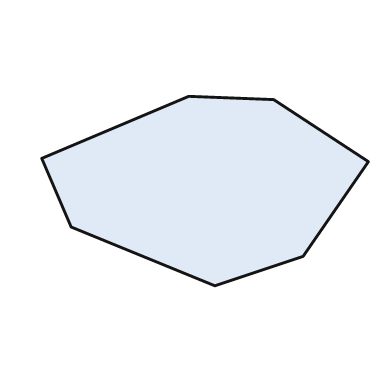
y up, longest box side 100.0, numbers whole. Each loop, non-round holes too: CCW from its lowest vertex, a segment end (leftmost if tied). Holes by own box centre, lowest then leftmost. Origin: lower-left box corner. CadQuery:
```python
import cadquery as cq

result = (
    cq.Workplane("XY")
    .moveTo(53.0, 0.0)
    .lineTo(80.0, 9.0)
    .lineTo(100.0, 38.0)
    .lineTo(71.0, 57.0)
    .lineTo(45.0, 58.0)
    .lineTo(0.0, 39.0)
    .lineTo(9.0, 18.0)
    .close()
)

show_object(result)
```